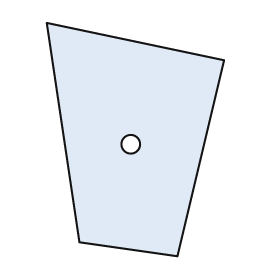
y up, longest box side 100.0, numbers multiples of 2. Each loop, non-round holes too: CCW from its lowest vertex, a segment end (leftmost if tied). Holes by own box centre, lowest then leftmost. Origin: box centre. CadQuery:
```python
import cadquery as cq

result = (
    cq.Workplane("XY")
    .moveTo(18.0, -50.0)
    .lineTo(38.0, 34.0)
    .lineTo(-38.0, 50.0)
    .lineTo(-24.0, -44.0)
    .close()
    .moveTo(-2.0, -2.0)
    .circle(4.0)
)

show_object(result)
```